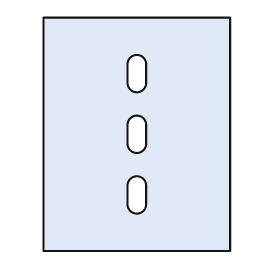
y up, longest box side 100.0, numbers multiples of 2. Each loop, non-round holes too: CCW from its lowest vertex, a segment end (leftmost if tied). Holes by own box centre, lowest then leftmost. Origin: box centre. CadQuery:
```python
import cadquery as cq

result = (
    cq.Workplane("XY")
    .moveTo(-40.0, -50.0)
    .lineTo(40.0, -50.0)
    .lineTo(40.0, 50.0)
    .lineTo(-40.0, 50.0)
    .close()
    .moveTo(-4.0, -30.0)
    .threePointArc((0.0, -34.0), (4.0, -30.0))
    .lineTo(4.0, -22.0)
    .threePointArc((0.0, -18.0), (-4.0, -22.0))
    .close()
    .moveTo(-4.0, -4.0)
    .threePointArc((0.0, -8.0), (4.0, -4.0))
    .lineTo(4.0, 4.0)
    .threePointArc((0.0, 8.0), (-4.0, 4.0))
    .close()
    .moveTo(-4.0, 22.0)
    .threePointArc((0.0, 18.0), (4.0, 22.0))
    .lineTo(4.0, 30.0)
    .threePointArc((0.0, 34.0), (-4.0, 30.0))
    .close()
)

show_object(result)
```